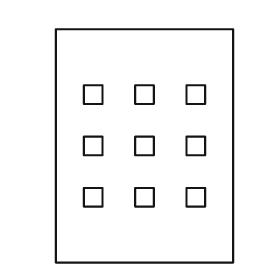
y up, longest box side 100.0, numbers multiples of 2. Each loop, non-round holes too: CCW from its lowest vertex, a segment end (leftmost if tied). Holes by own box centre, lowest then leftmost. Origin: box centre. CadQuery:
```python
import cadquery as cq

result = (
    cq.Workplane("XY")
    .moveTo(-38.0, -50.0)
    .lineTo(38.0, -50.0)
    .lineTo(38.0, 50.0)
    .lineTo(-38.0, 50.0)
    .close()
    .moveTo(-26.0, -26.0)
    .lineTo(-18.0, -26.0)
    .lineTo(-18.0, -18.0)
    .lineTo(-26.0, -18.0)
    .close()
    .moveTo(-4.0, -26.0)
    .lineTo(4.0, -26.0)
    .lineTo(4.0, -18.0)
    .lineTo(-4.0, -18.0)
    .close()
    .moveTo(18.0, -26.0)
    .lineTo(26.0, -26.0)
    .lineTo(26.0, -18.0)
    .lineTo(18.0, -18.0)
    .close()
    .moveTo(-26.0, -4.0)
    .lineTo(-18.0, -4.0)
    .lineTo(-18.0, 4.0)
    .lineTo(-26.0, 4.0)
    .close()
    .moveTo(-4.0, -4.0)
    .lineTo(4.0, -4.0)
    .lineTo(4.0, 4.0)
    .lineTo(-4.0, 4.0)
    .close()
    .moveTo(18.0, -4.0)
    .lineTo(26.0, -4.0)
    .lineTo(26.0, 4.0)
    .lineTo(18.0, 4.0)
    .close()
    .moveTo(-26.0, 18.0)
    .lineTo(-18.0, 18.0)
    .lineTo(-18.0, 26.0)
    .lineTo(-26.0, 26.0)
    .close()
    .moveTo(-4.0, 18.0)
    .lineTo(4.0, 18.0)
    .lineTo(4.0, 26.0)
    .lineTo(-4.0, 26.0)
    .close()
    .moveTo(18.0, 18.0)
    .lineTo(26.0, 18.0)
    .lineTo(26.0, 26.0)
    .lineTo(18.0, 26.0)
    .close()
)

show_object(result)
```